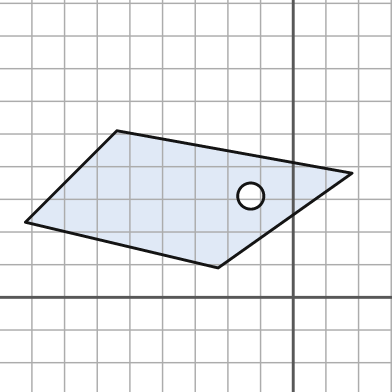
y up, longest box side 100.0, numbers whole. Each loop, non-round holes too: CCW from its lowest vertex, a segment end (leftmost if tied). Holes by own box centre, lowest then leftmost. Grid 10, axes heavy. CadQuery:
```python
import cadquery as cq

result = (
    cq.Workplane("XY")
    .moveTo(-23.0, 9.0)
    .lineTo(18.0, 38.0)
    .lineTo(-54.0, 51.0)
    .lineTo(-82.0, 23.0)
    .close()
    .moveTo(-13.0, 31.0)
    .circle(4.0)
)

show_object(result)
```